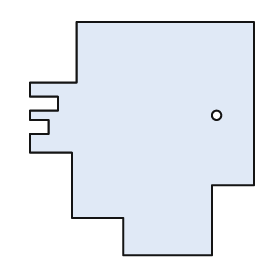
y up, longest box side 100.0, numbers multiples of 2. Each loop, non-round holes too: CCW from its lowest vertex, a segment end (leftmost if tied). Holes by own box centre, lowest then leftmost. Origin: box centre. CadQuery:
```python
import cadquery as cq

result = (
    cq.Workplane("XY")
    .moveTo(-8.0, -50.0)
    .lineTo(30.0, -50.0)
    .lineTo(30.0, -20.0)
    .lineTo(48.0, -20.0)
    .lineTo(48.0, 50.0)
    .lineTo(-28.0, 50.0)
    .lineTo(-28.0, 24.0)
    .lineTo(-48.0, 24.0)
    .lineTo(-48.0, 18.0)
    .lineTo(-36.0, 18.0)
    .lineTo(-36.0, 12.0)
    .lineTo(-48.0, 12.0)
    .lineTo(-48.0, 8.0)
    .lineTo(-40.0, 8.0)
    .lineTo(-40.0, 2.0)
    .lineTo(-48.0, 2.0)
    .lineTo(-48.0, -6.0)
    .lineTo(-30.0, -6.0)
    .lineTo(-30.0, -34.0)
    .lineTo(-8.0, -34.0)
    .close()
    .moveTo(32.0, 10.0)
    .circle(2.0)
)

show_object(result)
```